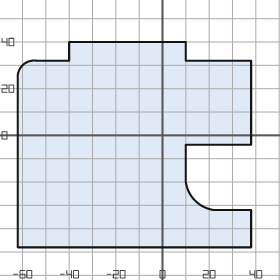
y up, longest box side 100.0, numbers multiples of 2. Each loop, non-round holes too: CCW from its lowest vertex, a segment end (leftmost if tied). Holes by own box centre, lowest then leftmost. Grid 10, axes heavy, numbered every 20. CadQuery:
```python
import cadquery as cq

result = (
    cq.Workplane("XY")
    .moveTo(-62.0, -48.0)
    .lineTo(38.0, -48.0)
    .lineTo(38.0, -32.0)
    .lineTo(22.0, -32.0)
    .threePointArc((14.0, -28.0), (10.0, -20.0))
    .lineTo(10.0, -4.0)
    .lineTo(38.0, -4.0)
    .lineTo(38.0, 32.0)
    .lineTo(10.0, 32.0)
    .lineTo(10.0, 40.0)
    .lineTo(-40.0, 40.0)
    .lineTo(-40.0, 32.0)
    .lineTo(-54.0, 32.0)
    .threePointArc((-60.0, 30.0), (-62.0, 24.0))
    .close()
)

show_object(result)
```